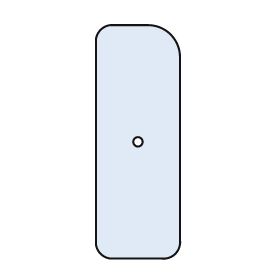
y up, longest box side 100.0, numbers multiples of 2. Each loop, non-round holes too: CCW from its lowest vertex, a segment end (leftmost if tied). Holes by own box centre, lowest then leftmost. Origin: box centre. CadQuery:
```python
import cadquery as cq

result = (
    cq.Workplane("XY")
    .moveTo(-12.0, -50.0)
    .lineTo(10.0, -50.0)
    .threePointArc((16.0, -48.0), (18.0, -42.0))
    .lineTo(18.0, 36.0)
    .threePointArc((14.0, 46.0), (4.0, 50.0))
    .lineTo(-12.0, 50.0)
    .threePointArc((-16.0, 48.0), (-18.0, 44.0))
    .lineTo(-18.0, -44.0)
    .threePointArc((-16.0, -48.0), (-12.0, -50.0))
    .close()
    .moveTo(0.0, 0.0)
    .circle(2.0)
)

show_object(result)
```